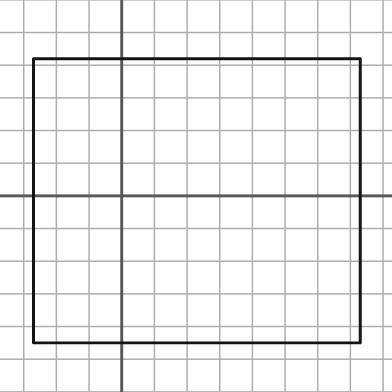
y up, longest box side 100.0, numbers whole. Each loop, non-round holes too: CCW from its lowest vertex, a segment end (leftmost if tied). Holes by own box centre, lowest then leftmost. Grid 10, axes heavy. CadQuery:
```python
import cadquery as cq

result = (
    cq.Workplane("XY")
    .moveTo(-27.0, -45.0)
    .lineTo(73.0, -45.0)
    .lineTo(73.0, 42.0)
    .lineTo(-27.0, 42.0)
    .close()
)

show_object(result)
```